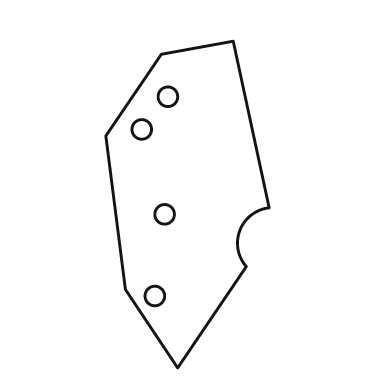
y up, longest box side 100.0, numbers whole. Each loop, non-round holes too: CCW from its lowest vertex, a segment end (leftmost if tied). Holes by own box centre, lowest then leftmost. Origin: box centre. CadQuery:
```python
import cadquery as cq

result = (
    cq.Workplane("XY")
    .moveTo(-3.0, -50.0)
    .lineTo(18.0, -19.0)
    .threePointArc((16.0, -8.0), (25.0, -1.0))
    .lineTo(14.0, 50.0)
    .lineTo(-8.0, 46.0)
    .lineTo(-25.0, 21.0)
    .lineTo(-19.0, -26.0)
    .close()
    .moveTo(-10.0, -28.0)
    .circle(3.0)
    .moveTo(-7.0, -3.0)
    .circle(3.0)
    .moveTo(-14.0, 23.0)
    .circle(3.0)
    .moveTo(-6.0, 33.0)
    .circle(3.0)
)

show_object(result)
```